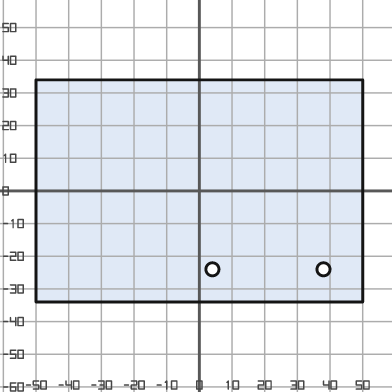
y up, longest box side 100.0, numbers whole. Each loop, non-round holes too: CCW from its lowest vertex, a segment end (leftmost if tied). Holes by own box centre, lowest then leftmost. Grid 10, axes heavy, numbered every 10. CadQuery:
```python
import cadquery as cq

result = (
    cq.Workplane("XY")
    .moveTo(-50.0, -34.0)
    .lineTo(50.0, -34.0)
    .lineTo(50.0, 34.0)
    .lineTo(-50.0, 34.0)
    .close()
    .moveTo(4.0, -24.0)
    .circle(2.0)
    .moveTo(38.0, -24.0)
    .circle(2.0)
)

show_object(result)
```